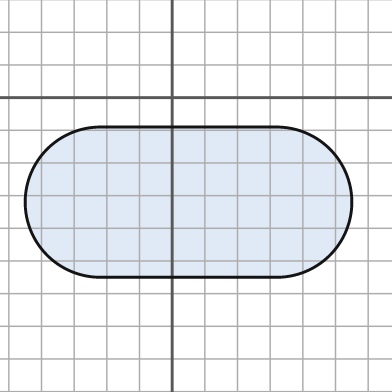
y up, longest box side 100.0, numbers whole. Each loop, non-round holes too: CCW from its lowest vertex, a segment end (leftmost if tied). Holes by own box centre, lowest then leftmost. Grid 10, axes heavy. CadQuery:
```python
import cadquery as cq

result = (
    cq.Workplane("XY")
    .moveTo(-22.0, -55.0)
    .lineTo(32.0, -55.0)
    .threePointArc((55.0, -32.0), (32.0, -9.0))
    .lineTo(-22.0, -9.0)
    .threePointArc((-45.0, -32.0), (-22.0, -55.0))
    .close()
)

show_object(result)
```